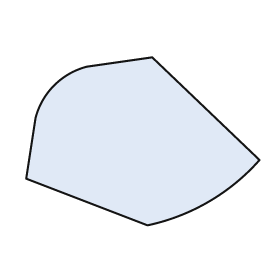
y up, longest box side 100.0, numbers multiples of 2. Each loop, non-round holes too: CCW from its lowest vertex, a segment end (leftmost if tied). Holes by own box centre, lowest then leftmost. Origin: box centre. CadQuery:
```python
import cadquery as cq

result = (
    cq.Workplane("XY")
    .moveTo(2.0, -36.0)
    .threePointArc((28.0, -26.0), (50.0, -8.0))
    .lineTo(4.0, 36.0)
    .lineTo(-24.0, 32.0)
    .threePointArc((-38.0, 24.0), (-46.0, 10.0))
    .lineTo(-50.0, -16.0)
    .close()
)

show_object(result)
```